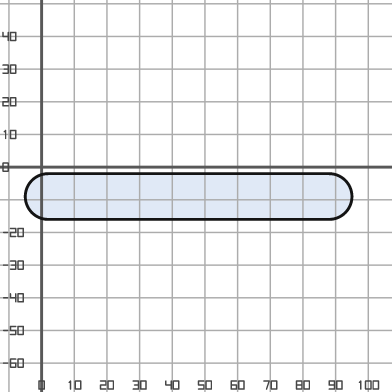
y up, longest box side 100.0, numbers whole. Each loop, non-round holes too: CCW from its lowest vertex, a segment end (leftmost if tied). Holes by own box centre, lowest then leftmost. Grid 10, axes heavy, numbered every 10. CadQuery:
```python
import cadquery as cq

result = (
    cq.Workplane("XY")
    .moveTo(2.0, -16.0)
    .lineTo(88.0, -16.0)
    .threePointArc((95.0, -9.0), (88.0, -2.0))
    .lineTo(2.0, -2.0)
    .threePointArc((-5.0, -9.0), (2.0, -16.0))
    .close()
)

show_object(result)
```